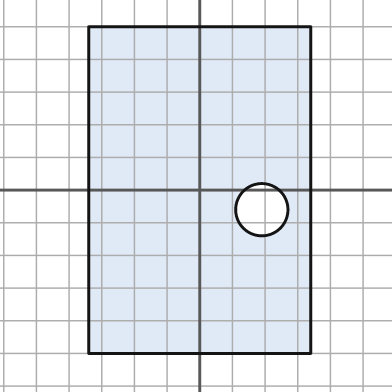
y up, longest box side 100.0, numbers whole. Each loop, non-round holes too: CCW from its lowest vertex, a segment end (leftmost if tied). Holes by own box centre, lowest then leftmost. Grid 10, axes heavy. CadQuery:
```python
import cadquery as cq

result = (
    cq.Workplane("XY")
    .moveTo(-34.0, -50.0)
    .lineTo(34.0, -50.0)
    .lineTo(34.0, 50.0)
    .lineTo(-34.0, 50.0)
    .close()
    .moveTo(19.0, -6.0)
    .circle(8.0)
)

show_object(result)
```